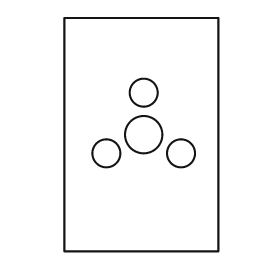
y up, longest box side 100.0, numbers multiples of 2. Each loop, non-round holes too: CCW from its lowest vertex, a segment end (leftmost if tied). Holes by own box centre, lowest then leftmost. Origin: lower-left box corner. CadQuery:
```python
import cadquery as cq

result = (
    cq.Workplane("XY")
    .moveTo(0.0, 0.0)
    .lineTo(66.0, 0.0)
    .lineTo(66.0, 100.0)
    .lineTo(0.0, 100.0)
    .close()
    .moveTo(18.0, 42.0)
    .circle(6.0)
    .moveTo(50.0, 42.0)
    .circle(6.0)
    .moveTo(34.0, 50.0)
    .circle(8.0)
    .moveTo(34.0, 68.0)
    .circle(6.0)
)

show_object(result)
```